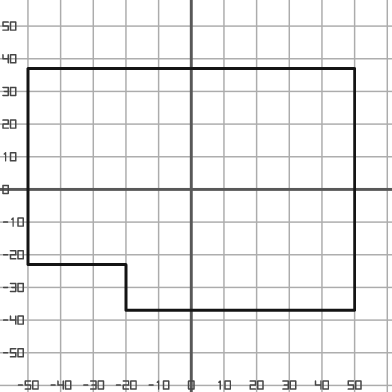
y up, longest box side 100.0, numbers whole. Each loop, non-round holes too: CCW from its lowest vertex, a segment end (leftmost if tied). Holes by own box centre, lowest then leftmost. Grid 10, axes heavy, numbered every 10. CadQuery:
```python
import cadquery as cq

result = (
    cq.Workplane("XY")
    .moveTo(-20.0, -37.0)
    .lineTo(50.0, -37.0)
    .lineTo(50.0, 37.0)
    .lineTo(-50.0, 37.0)
    .lineTo(-50.0, -23.0)
    .lineTo(-20.0, -23.0)
    .close()
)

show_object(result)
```